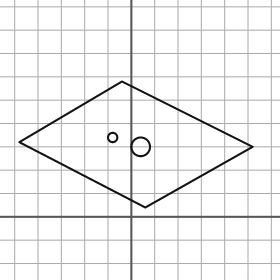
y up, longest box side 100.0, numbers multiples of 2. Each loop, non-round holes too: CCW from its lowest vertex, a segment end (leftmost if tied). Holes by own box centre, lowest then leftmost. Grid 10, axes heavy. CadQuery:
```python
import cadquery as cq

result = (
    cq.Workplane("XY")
    .moveTo(6.0, 4.0)
    .lineTo(52.0, 30.0)
    .lineTo(-4.0, 58.0)
    .lineTo(-48.0, 32.0)
    .close()
    .moveTo(4.0, 30.0)
    .circle(4.0)
    .moveTo(-8.0, 34.0)
    .circle(2.0)
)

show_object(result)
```